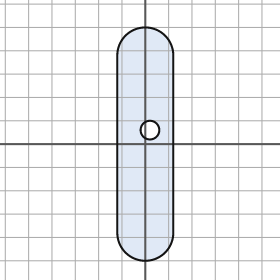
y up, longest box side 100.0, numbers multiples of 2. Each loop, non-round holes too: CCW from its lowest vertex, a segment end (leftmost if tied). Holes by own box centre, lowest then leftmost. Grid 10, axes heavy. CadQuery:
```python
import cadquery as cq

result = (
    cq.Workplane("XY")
    .moveTo(-12.0, -38.0)
    .threePointArc((0.0, -50.0), (12.0, -38.0))
    .lineTo(12.0, 38.0)
    .threePointArc((0.0, 50.0), (-12.0, 38.0))
    .close()
    .moveTo(2.0, 6.0)
    .circle(4.0)
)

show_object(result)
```